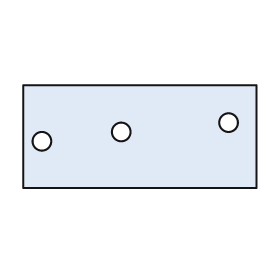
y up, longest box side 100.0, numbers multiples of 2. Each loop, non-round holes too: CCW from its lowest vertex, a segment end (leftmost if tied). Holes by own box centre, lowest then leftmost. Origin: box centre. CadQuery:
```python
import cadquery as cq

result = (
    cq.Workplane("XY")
    .moveTo(-50.0, -22.0)
    .lineTo(50.0, -22.0)
    .lineTo(50.0, 22.0)
    .lineTo(-50.0, 22.0)
    .close()
    .moveTo(-42.0, -2.0)
    .circle(4.0)
    .moveTo(-8.0, 2.0)
    .circle(4.0)
    .moveTo(38.0, 6.0)
    .circle(4.0)
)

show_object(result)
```